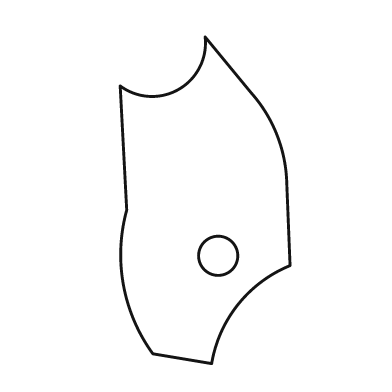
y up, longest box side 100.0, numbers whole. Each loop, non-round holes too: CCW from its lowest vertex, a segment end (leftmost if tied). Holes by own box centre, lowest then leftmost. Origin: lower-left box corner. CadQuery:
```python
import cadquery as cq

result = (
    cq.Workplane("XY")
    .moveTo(28.0, 0.0)
    .threePointArc((36.0, 18.0), (52.0, 30.0))
    .lineTo(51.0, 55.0)
    .threePointArc((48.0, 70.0), (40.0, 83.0))
    .lineTo(26.0, 100.0)
    .threePointArc((18.0, 84.0), (0.0, 85.0))
    .lineTo(2.0, 47.0)
    .threePointArc((1.0, 24.0), (10.0, 3.0))
    .close()
    .moveTo(30.0, 33.0)
    .circle(6.0)
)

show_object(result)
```